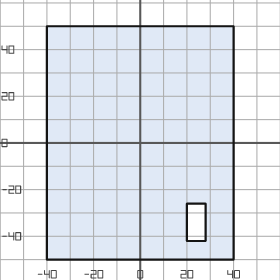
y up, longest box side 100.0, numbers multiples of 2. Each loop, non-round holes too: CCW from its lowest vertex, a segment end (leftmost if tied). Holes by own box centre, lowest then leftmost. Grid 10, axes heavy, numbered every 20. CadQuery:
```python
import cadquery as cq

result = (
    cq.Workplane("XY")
    .moveTo(-40.0, -50.0)
    .lineTo(40.0, -50.0)
    .lineTo(40.0, 50.0)
    .lineTo(-40.0, 50.0)
    .close()
    .moveTo(20.0, -42.0)
    .lineTo(28.0, -42.0)
    .lineTo(28.0, -26.0)
    .lineTo(20.0, -26.0)
    .close()
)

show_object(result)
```